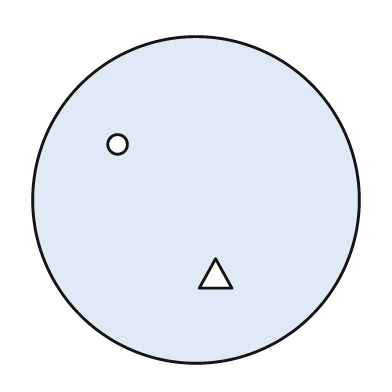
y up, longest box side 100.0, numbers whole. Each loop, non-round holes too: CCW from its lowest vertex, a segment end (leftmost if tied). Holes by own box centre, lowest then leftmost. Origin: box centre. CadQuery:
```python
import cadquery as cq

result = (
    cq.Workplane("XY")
    .moveTo(0.0, 0.0)
    .circle(50.0)
    .moveTo(1.0, -27.0)
    .lineTo(11.0, -27.0)
    .lineTo(6.0, -18.0)
    .close()
    .moveTo(-24.0, 17.0)
    .circle(3.0)
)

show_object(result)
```